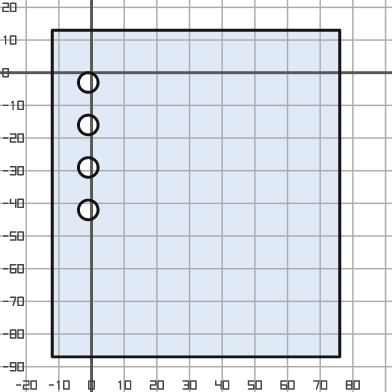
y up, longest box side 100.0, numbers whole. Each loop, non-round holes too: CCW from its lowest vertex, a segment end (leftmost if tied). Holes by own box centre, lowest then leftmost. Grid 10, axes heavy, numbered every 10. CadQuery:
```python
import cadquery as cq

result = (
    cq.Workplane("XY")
    .moveTo(-12.0, -87.0)
    .lineTo(76.0, -87.0)
    .lineTo(76.0, 13.0)
    .lineTo(-12.0, 13.0)
    .close()
    .moveTo(-1.0, -42.0)
    .circle(3.0)
    .moveTo(-1.0, -29.0)
    .circle(3.0)
    .moveTo(-1.0, -16.0)
    .circle(3.0)
    .moveTo(-1.0, -3.0)
    .circle(3.0)
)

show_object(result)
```